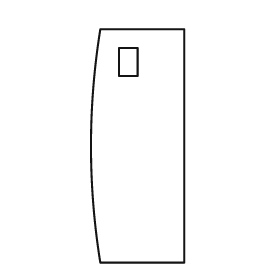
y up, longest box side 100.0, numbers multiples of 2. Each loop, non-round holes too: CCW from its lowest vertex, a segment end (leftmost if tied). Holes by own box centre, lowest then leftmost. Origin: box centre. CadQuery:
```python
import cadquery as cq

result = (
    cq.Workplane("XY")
    .moveTo(-16.0, -50.0)
    .lineTo(20.0, -50.0)
    .lineTo(20.0, 50.0)
    .lineTo(-16.0, 50.0)
    .threePointArc((-20.0, 0.0), (-16.0, -50.0))
    .close()
    .moveTo(-8.0, 30.0)
    .lineTo(0.0, 30.0)
    .lineTo(0.0, 42.0)
    .lineTo(-8.0, 42.0)
    .close()
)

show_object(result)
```